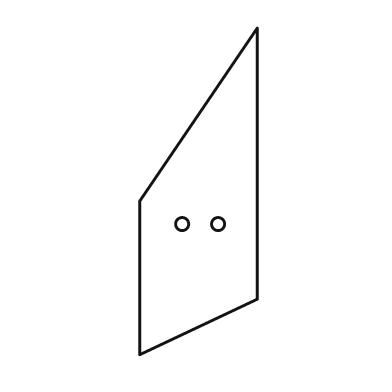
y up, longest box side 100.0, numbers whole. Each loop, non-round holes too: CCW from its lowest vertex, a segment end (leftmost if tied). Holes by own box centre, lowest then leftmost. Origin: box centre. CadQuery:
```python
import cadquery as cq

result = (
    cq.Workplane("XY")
    .moveTo(-18.0, -50.0)
    .lineTo(18.0, -33.0)
    .lineTo(18.0, 50.0)
    .lineTo(-18.0, -3.0)
    .close()
    .moveTo(-5.0, -10.0)
    .circle(2.0)
    .moveTo(6.0, -10.0)
    .circle(2.0)
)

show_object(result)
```